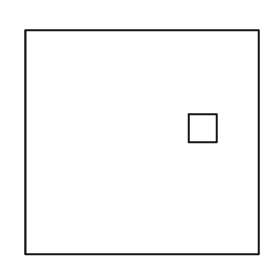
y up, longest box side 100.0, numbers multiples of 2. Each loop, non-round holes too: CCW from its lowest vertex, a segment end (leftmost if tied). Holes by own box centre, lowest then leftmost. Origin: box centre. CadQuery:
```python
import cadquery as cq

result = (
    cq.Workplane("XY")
    .moveTo(-50.0, -48.0)
    .lineTo(50.0, -48.0)
    .lineTo(50.0, 48.0)
    .lineTo(-50.0, 48.0)
    .close()
    .moveTo(20.0, 0.0)
    .lineTo(32.0, 0.0)
    .lineTo(32.0, 12.0)
    .lineTo(20.0, 12.0)
    .close()
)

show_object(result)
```